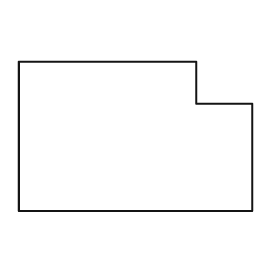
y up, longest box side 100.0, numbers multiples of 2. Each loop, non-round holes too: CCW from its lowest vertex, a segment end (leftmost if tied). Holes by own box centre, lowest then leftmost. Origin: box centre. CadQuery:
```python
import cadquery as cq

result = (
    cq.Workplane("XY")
    .moveTo(-50.0, -32.0)
    .lineTo(50.0, -32.0)
    .lineTo(50.0, 14.0)
    .lineTo(26.0, 14.0)
    .lineTo(26.0, 32.0)
    .lineTo(-50.0, 32.0)
    .close()
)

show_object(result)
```